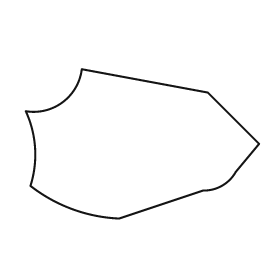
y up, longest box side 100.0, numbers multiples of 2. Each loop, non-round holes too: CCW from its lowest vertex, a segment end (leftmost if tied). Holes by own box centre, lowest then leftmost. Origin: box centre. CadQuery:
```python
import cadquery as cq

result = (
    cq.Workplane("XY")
    .moveTo(-10.0, -32.0)
    .lineTo(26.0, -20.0)
    .threePointArc((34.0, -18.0), (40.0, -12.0))
    .lineTo(50.0, 0.0)
    .lineTo(28.0, 22.0)
    .lineTo(-26.0, 32.0)
    .threePointArc((-34.0, 18.0), (-50.0, 14.0))
    .threePointArc((-46.0, -2.0), (-48.0, -18.0))
    .threePointArc((-30.0, -28.0), (-10.0, -32.0))
    .close()
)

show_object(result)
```